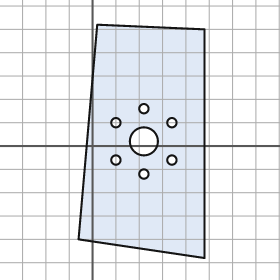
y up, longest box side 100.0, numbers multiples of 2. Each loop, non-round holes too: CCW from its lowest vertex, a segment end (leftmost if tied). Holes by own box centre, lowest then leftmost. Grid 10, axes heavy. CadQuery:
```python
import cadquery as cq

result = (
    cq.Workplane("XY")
    .moveTo(48.0, -48.0)
    .lineTo(48.0, 50.0)
    .lineTo(2.0, 52.0)
    .lineTo(-6.0, -40.0)
    .close()
    .moveTo(22.0, -12.0)
    .circle(2.0)
    .moveTo(10.0, -6.0)
    .circle(2.0)
    .moveTo(34.0, -6.0)
    .circle(2.0)
    .moveTo(22.0, 2.0)
    .circle(6.0)
    .moveTo(10.0, 10.0)
    .circle(2.0)
    .moveTo(34.0, 10.0)
    .circle(2.0)
    .moveTo(22.0, 16.0)
    .circle(2.0)
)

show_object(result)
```